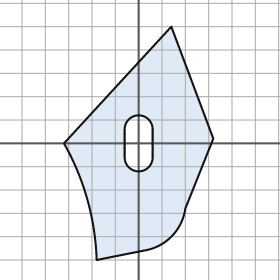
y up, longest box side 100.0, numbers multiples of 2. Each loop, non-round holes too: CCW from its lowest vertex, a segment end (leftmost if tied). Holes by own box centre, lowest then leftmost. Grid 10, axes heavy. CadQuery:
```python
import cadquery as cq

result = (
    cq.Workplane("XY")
    .moveTo(-18.0, -50.0)
    .lineTo(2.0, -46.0)
    .threePointArc((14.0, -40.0), (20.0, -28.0))
    .lineTo(32.0, 2.0)
    .lineTo(14.0, 50.0)
    .lineTo(-32.0, 0.0)
    .threePointArc((-22.0, -24.0), (-18.0, -50.0))
    .close()
    .moveTo(-6.0, -6.0)
    .threePointArc((0.0, -12.0), (6.0, -6.0))
    .lineTo(6.0, 6.0)
    .threePointArc((0.0, 12.0), (-6.0, 6.0))
    .close()
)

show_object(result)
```